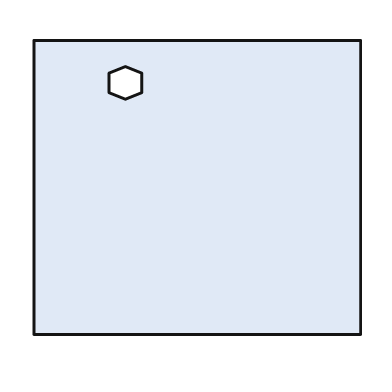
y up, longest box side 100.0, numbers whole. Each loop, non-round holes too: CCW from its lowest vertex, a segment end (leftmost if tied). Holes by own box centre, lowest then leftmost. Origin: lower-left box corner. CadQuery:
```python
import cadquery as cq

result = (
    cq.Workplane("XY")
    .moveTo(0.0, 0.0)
    .lineTo(100.0, 0.0)
    .lineTo(100.0, 90.0)
    .lineTo(0.0, 90.0)
    .close()
    .moveTo(28.0, 72.0)
    .lineTo(33.0, 74.0)
    .lineTo(33.0, 80.0)
    .lineTo(28.0, 82.0)
    .lineTo(23.0, 80.0)
    .lineTo(23.0, 74.0)
    .close()
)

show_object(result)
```